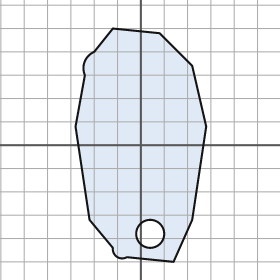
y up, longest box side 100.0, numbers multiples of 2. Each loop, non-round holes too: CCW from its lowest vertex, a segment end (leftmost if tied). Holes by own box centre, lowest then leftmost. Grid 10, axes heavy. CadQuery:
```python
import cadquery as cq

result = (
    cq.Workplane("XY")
    .moveTo(14.0, -50.0)
    .lineTo(22.0, -32.0)
    .lineTo(28.0, 8.0)
    .lineTo(22.0, 34.0)
    .lineTo(8.0, 48.0)
    .lineTo(-12.0, 50.0)
    .lineTo(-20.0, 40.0)
    .threePointArc((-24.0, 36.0), (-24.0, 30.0))
    .lineTo(-28.0, 8.0)
    .lineTo(-22.0, -32.0)
    .lineTo(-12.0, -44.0)
    .threePointArc((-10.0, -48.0), (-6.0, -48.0))
    .close()
    .moveTo(4.0, -38.0)
    .circle(6.0)
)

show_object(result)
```